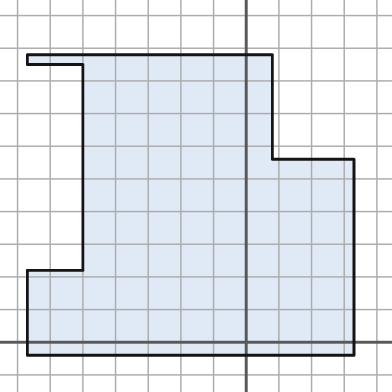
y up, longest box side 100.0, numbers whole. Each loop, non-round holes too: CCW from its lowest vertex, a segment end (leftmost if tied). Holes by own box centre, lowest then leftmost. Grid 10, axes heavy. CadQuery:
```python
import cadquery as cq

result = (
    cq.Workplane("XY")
    .moveTo(-67.0, -4.0)
    .lineTo(33.0, -4.0)
    .lineTo(33.0, 56.0)
    .lineTo(8.0, 56.0)
    .lineTo(8.0, 88.0)
    .lineTo(-67.0, 88.0)
    .lineTo(-67.0, 85.0)
    .lineTo(-50.0, 85.0)
    .lineTo(-50.0, 22.0)
    .lineTo(-67.0, 22.0)
    .close()
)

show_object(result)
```